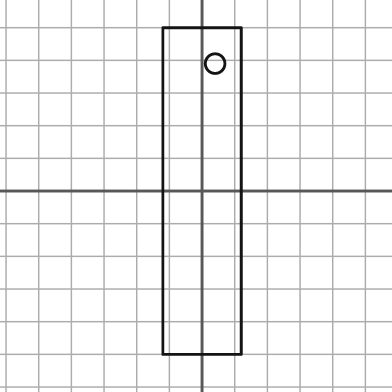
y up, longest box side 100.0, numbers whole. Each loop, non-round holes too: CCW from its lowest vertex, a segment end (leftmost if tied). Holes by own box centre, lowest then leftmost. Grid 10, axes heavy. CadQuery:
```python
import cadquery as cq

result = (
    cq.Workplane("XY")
    .moveTo(-12.0, -50.0)
    .lineTo(12.0, -50.0)
    .lineTo(12.0, 50.0)
    .lineTo(-12.0, 50.0)
    .close()
    .moveTo(4.0, 39.0)
    .circle(3.0)
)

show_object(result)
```